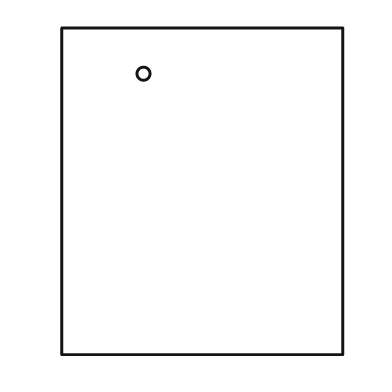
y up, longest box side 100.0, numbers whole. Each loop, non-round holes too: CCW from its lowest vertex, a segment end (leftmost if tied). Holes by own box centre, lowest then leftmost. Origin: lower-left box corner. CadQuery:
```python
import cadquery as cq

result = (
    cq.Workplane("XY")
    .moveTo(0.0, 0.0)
    .lineTo(86.0, 0.0)
    .lineTo(86.0, 100.0)
    .lineTo(0.0, 100.0)
    .close()
    .moveTo(25.0, 86.0)
    .circle(2.0)
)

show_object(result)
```